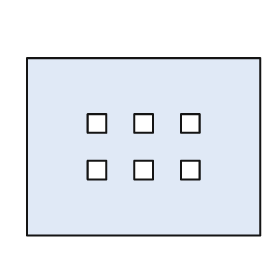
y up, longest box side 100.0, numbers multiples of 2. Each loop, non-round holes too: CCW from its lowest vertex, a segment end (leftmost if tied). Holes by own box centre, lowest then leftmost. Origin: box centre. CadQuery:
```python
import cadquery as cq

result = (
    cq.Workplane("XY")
    .moveTo(-50.0, -38.0)
    .lineTo(50.0, -38.0)
    .lineTo(50.0, 38.0)
    .lineTo(-50.0, 38.0)
    .close()
    .moveTo(-24.0, -14.0)
    .lineTo(-16.0, -14.0)
    .lineTo(-16.0, -6.0)
    .lineTo(-24.0, -6.0)
    .close()
    .moveTo(-4.0, -14.0)
    .lineTo(4.0, -14.0)
    .lineTo(4.0, -6.0)
    .lineTo(-4.0, -6.0)
    .close()
    .moveTo(16.0, -14.0)
    .lineTo(24.0, -14.0)
    .lineTo(24.0, -6.0)
    .lineTo(16.0, -6.0)
    .close()
    .moveTo(-24.0, 6.0)
    .lineTo(-16.0, 6.0)
    .lineTo(-16.0, 14.0)
    .lineTo(-24.0, 14.0)
    .close()
    .moveTo(-4.0, 6.0)
    .lineTo(4.0, 6.0)
    .lineTo(4.0, 14.0)
    .lineTo(-4.0, 14.0)
    .close()
    .moveTo(16.0, 6.0)
    .lineTo(24.0, 6.0)
    .lineTo(24.0, 14.0)
    .lineTo(16.0, 14.0)
    .close()
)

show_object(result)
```